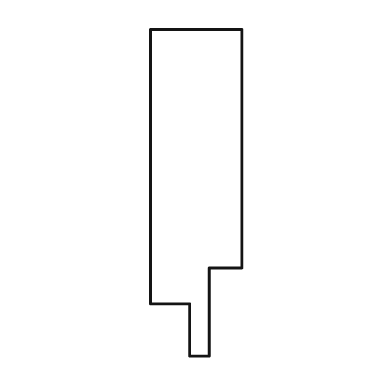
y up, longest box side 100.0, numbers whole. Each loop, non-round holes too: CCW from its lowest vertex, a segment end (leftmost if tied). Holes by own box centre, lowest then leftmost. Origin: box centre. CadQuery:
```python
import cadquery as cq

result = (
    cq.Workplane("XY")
    .moveTo(-2.0, -50.0)
    .lineTo(4.0, -50.0)
    .lineTo(4.0, -23.0)
    .lineTo(14.0, -23.0)
    .lineTo(14.0, 50.0)
    .lineTo(-14.0, 50.0)
    .lineTo(-14.0, -34.0)
    .lineTo(-2.0, -34.0)
    .close()
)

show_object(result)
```